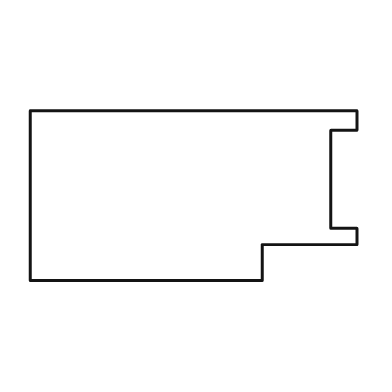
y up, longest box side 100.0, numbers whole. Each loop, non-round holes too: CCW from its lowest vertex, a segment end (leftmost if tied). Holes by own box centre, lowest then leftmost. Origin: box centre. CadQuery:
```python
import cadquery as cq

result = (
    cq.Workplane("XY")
    .moveTo(-50.0, -26.0)
    .lineTo(21.0, -26.0)
    .lineTo(21.0, -15.0)
    .lineTo(50.0, -15.0)
    .lineTo(50.0, -10.0)
    .lineTo(42.0, -10.0)
    .lineTo(42.0, 20.0)
    .lineTo(50.0, 20.0)
    .lineTo(50.0, 26.0)
    .lineTo(-50.0, 26.0)
    .close()
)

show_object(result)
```